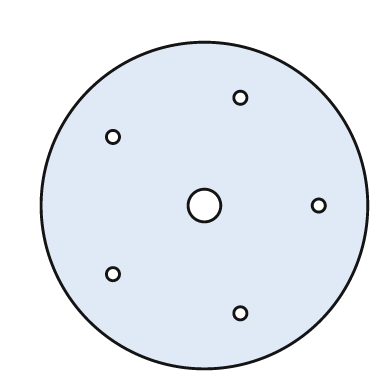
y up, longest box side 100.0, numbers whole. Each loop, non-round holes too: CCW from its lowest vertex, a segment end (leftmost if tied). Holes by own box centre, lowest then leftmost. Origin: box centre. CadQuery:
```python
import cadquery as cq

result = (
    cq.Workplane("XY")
    .moveTo(0.0, 0.0)
    .circle(50.0)
    .moveTo(11.0, -33.0)
    .circle(2.0)
    .moveTo(-28.0, -21.0)
    .circle(2.0)
    .moveTo(0.0, 0.0)
    .circle(5.0)
    .moveTo(35.0, 0.0)
    .circle(2.0)
    .moveTo(-28.0, 21.0)
    .circle(2.0)
    .moveTo(11.0, 33.0)
    .circle(2.0)
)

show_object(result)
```